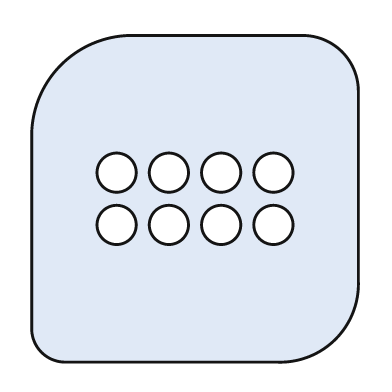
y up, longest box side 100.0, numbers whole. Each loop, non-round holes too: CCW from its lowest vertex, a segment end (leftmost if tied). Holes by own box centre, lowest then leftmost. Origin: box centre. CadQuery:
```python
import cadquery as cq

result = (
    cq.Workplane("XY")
    .moveTo(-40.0, -50.0)
    .lineTo(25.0, -50.0)
    .threePointArc((43.0, -43.0), (50.0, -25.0))
    .lineTo(50.0, 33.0)
    .threePointArc((45.0, 45.0), (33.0, 50.0))
    .lineTo(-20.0, 50.0)
    .threePointArc((-41.0, 41.0), (-50.0, 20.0))
    .lineTo(-50.0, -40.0)
    .threePointArc((-47.0, -47.0), (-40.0, -50.0))
    .close()
    .moveTo(-24.0, -8.0)
    .circle(6.0)
    .moveTo(-8.0, -8.0)
    .circle(6.0)
    .moveTo(8.0, -8.0)
    .circle(6.0)
    .moveTo(24.0, -8.0)
    .circle(6.0)
    .moveTo(-24.0, 8.0)
    .circle(6.0)
    .moveTo(-8.0, 8.0)
    .circle(6.0)
    .moveTo(8.0, 8.0)
    .circle(6.0)
    .moveTo(24.0, 8.0)
    .circle(6.0)
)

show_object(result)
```